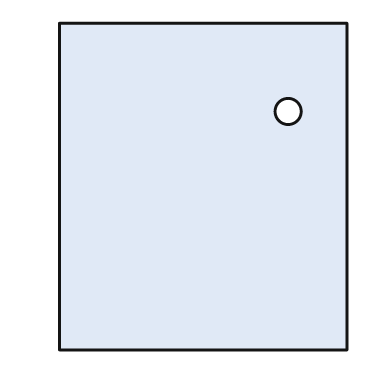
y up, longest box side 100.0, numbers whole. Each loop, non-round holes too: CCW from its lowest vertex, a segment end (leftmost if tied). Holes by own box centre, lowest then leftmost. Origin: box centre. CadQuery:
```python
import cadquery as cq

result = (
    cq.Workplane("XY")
    .moveTo(-44.0, -50.0)
    .lineTo(44.0, -50.0)
    .lineTo(44.0, 50.0)
    .lineTo(-44.0, 50.0)
    .close()
    .moveTo(26.0, 23.0)
    .circle(4.0)
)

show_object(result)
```